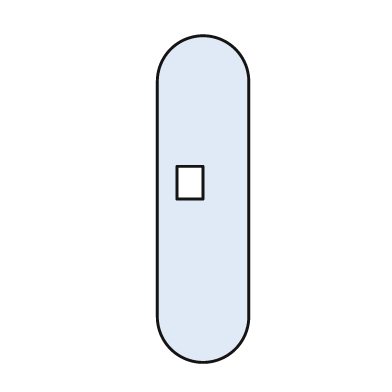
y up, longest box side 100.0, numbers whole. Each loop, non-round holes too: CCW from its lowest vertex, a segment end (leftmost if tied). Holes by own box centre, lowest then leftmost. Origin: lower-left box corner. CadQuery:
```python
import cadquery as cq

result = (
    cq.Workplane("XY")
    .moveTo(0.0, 14.0)
    .threePointArc((14.0, 0.0), (28.0, 14.0))
    .lineTo(28.0, 86.0)
    .threePointArc((14.0, 100.0), (0.0, 86.0))
    .close()
    .moveTo(6.0, 50.0)
    .lineTo(14.0, 50.0)
    .lineTo(14.0, 60.0)
    .lineTo(6.0, 60.0)
    .close()
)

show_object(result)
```